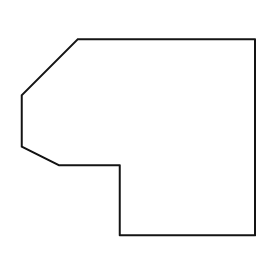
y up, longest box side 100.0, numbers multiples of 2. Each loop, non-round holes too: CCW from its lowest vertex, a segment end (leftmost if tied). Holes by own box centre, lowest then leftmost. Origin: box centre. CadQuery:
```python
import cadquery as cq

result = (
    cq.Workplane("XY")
    .moveTo(-8.0, -42.0)
    .lineTo(50.0, -42.0)
    .lineTo(50.0, 42.0)
    .lineTo(-26.0, 42.0)
    .lineTo(-50.0, 18.0)
    .lineTo(-50.0, -4.0)
    .lineTo(-34.0, -12.0)
    .lineTo(-8.0, -12.0)
    .close()
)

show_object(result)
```